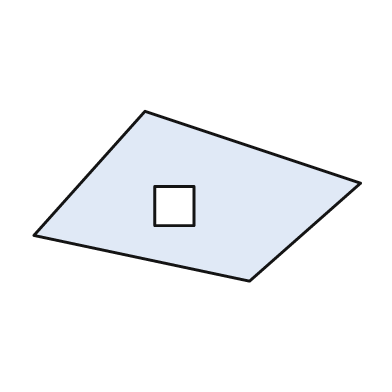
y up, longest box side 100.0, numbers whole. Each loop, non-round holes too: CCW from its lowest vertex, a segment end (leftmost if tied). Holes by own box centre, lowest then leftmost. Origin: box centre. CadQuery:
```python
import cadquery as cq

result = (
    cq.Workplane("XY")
    .moveTo(16.0, -26.0)
    .lineTo(50.0, 4.0)
    .lineTo(-16.0, 26.0)
    .lineTo(-50.0, -12.0)
    .close()
    .moveTo(-13.0, -9.0)
    .lineTo(-1.0, -9.0)
    .lineTo(-1.0, 3.0)
    .lineTo(-13.0, 3.0)
    .close()
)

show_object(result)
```